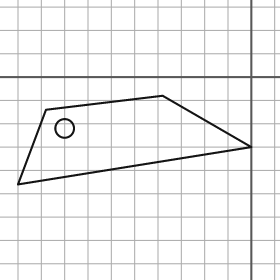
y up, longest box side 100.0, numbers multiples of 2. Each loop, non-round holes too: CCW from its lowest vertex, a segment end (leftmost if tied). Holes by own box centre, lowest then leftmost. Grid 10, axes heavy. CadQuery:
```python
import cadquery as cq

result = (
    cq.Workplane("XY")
    .moveTo(-100.0, -46.0)
    .lineTo(0.0, -30.0)
    .lineTo(-38.0, -8.0)
    .lineTo(-88.0, -14.0)
    .close()
    .moveTo(-80.0, -22.0)
    .circle(4.0)
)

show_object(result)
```